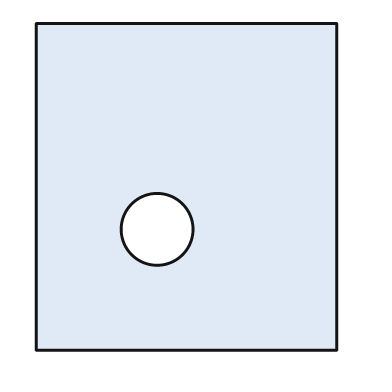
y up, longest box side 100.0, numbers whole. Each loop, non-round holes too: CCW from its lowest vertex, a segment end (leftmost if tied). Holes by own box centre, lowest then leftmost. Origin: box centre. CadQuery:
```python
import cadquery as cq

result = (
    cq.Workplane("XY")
    .moveTo(-46.0, -50.0)
    .lineTo(46.0, -50.0)
    .lineTo(46.0, 50.0)
    .lineTo(-46.0, 50.0)
    .close()
    .moveTo(-9.0, -13.0)
    .circle(11.0)
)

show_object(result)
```